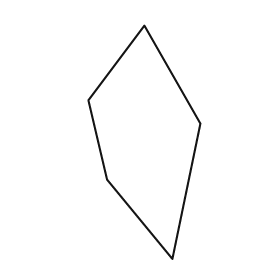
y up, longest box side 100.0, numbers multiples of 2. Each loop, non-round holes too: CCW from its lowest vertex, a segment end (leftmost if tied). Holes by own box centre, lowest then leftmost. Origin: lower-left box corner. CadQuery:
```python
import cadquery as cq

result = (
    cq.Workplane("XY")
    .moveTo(36.0, 0.0)
    .lineTo(48.0, 58.0)
    .lineTo(24.0, 100.0)
    .lineTo(0.0, 68.0)
    .lineTo(8.0, 34.0)
    .close()
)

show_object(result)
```